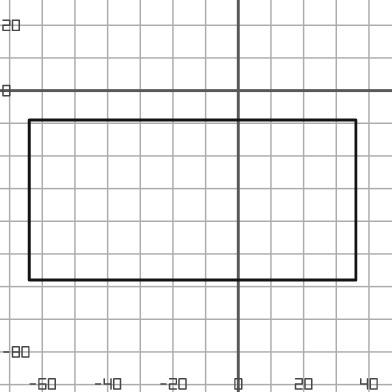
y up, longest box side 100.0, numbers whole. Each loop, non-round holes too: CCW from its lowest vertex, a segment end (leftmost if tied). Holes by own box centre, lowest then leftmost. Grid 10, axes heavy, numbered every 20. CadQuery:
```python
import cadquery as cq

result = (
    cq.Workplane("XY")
    .moveTo(-64.0, -58.0)
    .lineTo(36.0, -58.0)
    .lineTo(36.0, -9.0)
    .lineTo(-64.0, -9.0)
    .close()
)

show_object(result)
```